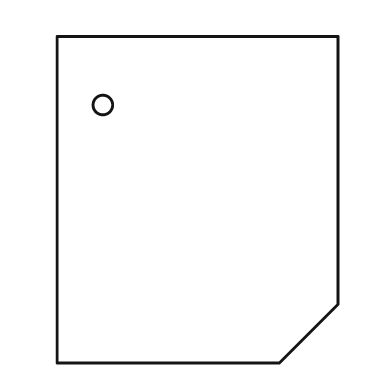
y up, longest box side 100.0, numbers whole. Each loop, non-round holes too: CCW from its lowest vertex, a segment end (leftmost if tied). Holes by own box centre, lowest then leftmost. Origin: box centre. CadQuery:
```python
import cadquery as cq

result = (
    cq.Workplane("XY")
    .moveTo(-43.0, -50.0)
    .lineTo(25.0, -50.0)
    .lineTo(43.0, -32.0)
    .lineTo(43.0, 50.0)
    .lineTo(-43.0, 50.0)
    .close()
    .moveTo(-29.0, 29.0)
    .circle(3.0)
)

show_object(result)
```